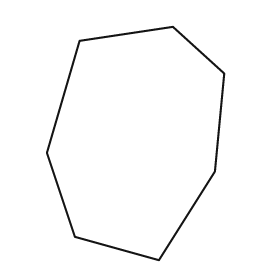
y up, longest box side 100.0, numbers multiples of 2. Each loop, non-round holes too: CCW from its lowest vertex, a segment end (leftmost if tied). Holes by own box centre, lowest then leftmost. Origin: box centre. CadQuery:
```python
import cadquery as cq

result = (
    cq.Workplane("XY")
    .moveTo(10.0, -50.0)
    .lineTo(34.0, -12.0)
    .lineTo(38.0, 30.0)
    .lineTo(16.0, 50.0)
    .lineTo(-24.0, 44.0)
    .lineTo(-38.0, -4.0)
    .lineTo(-26.0, -40.0)
    .close()
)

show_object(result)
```